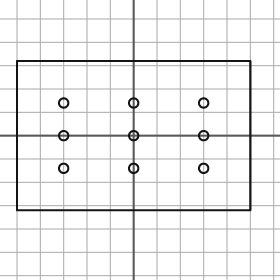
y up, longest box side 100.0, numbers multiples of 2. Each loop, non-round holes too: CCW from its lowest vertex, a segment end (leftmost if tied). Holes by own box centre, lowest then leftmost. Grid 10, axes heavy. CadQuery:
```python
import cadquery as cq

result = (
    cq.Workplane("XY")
    .moveTo(-50.0, -32.0)
    .lineTo(50.0, -32.0)
    .lineTo(50.0, 32.0)
    .lineTo(-50.0, 32.0)
    .close()
    .moveTo(-30.0, -14.0)
    .circle(2.0)
    .moveTo(0.0, -14.0)
    .circle(2.0)
    .moveTo(30.0, -14.0)
    .circle(2.0)
    .moveTo(-30.0, 0.0)
    .circle(2.0)
    .moveTo(0.0, 0.0)
    .circle(2.0)
    .moveTo(30.0, 0.0)
    .circle(2.0)
    .moveTo(-30.0, 14.0)
    .circle(2.0)
    .moveTo(0.0, 14.0)
    .circle(2.0)
    .moveTo(30.0, 14.0)
    .circle(2.0)
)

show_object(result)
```